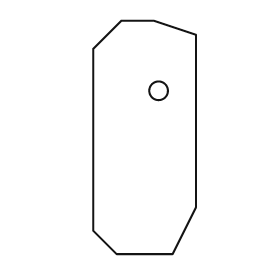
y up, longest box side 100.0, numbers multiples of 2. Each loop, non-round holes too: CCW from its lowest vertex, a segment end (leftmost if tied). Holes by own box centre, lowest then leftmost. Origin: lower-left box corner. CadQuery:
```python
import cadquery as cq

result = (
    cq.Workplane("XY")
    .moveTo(10.0, 0.0)
    .lineTo(34.0, 0.0)
    .lineTo(44.0, 20.0)
    .lineTo(44.0, 94.0)
    .lineTo(26.0, 100.0)
    .lineTo(12.0, 100.0)
    .lineTo(0.0, 88.0)
    .lineTo(0.0, 10.0)
    .close()
    .moveTo(28.0, 70.0)
    .circle(4.0)
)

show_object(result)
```